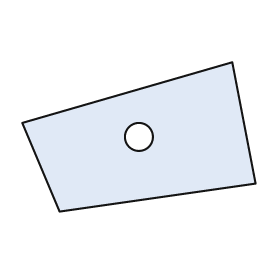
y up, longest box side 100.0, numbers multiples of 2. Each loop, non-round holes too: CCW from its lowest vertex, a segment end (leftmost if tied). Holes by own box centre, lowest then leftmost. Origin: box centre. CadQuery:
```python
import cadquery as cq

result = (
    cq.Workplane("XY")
    .moveTo(-34.0, -32.0)
    .lineTo(50.0, -20.0)
    .lineTo(40.0, 32.0)
    .lineTo(-50.0, 6.0)
    .close()
    .moveTo(0.0, 0.0)
    .circle(6.0)
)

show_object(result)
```